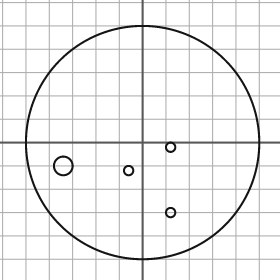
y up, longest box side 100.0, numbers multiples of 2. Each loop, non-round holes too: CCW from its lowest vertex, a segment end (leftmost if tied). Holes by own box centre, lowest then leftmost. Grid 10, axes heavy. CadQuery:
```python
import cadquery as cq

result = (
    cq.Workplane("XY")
    .moveTo(0.0, 0.0)
    .circle(50.0)
    .moveTo(12.0, -30.0)
    .circle(2.0)
    .moveTo(-6.0, -12.0)
    .circle(2.0)
    .moveTo(-34.0, -10.0)
    .circle(4.0)
    .moveTo(12.0, -2.0)
    .circle(2.0)
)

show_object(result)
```